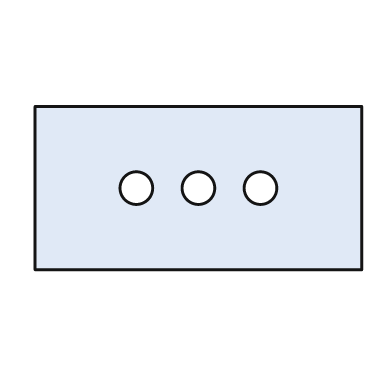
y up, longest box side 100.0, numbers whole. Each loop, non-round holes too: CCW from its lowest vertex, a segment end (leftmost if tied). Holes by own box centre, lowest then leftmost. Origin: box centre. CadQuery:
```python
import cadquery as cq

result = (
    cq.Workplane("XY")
    .moveTo(-50.0, -25.0)
    .lineTo(50.0, -25.0)
    .lineTo(50.0, 25.0)
    .lineTo(-50.0, 25.0)
    .close()
    .moveTo(-19.0, 0.0)
    .circle(5.0)
    .moveTo(0.0, 0.0)
    .circle(5.0)
    .moveTo(19.0, 0.0)
    .circle(5.0)
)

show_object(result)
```